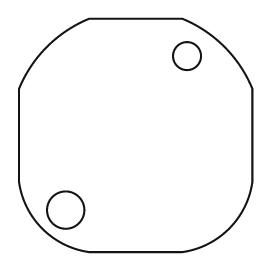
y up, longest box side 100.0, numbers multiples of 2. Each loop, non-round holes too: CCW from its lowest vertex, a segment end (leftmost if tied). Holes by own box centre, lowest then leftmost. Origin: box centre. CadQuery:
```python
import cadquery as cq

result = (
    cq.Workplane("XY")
    .moveTo(-20.0, -50.0)
    .lineTo(20.0, -50.0)
    .threePointArc((40.0, -40.0), (50.0, -20.0))
    .lineTo(50.0, 20.0)
    .threePointArc((38.0, 38.0), (20.0, 50.0))
    .lineTo(-20.0, 50.0)
    .threePointArc((-38.0, 38.0), (-50.0, 20.0))
    .lineTo(-50.0, -20.0)
    .threePointArc((-40.0, -40.0), (-20.0, -50.0))
    .close()
    .moveTo(-30.0, -32.0)
    .circle(8.0)
    .moveTo(22.0, 34.0)
    .circle(6.0)
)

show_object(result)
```